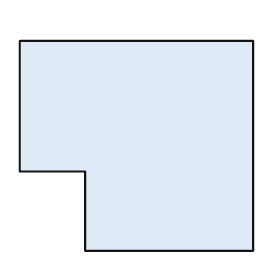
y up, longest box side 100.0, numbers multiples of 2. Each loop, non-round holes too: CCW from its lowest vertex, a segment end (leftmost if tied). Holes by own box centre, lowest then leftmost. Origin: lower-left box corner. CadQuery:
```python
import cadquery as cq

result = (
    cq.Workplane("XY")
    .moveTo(28.0, 0.0)
    .lineTo(100.0, 0.0)
    .lineTo(100.0, 90.0)
    .lineTo(0.0, 90.0)
    .lineTo(0.0, 34.0)
    .lineTo(28.0, 34.0)
    .close()
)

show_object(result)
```